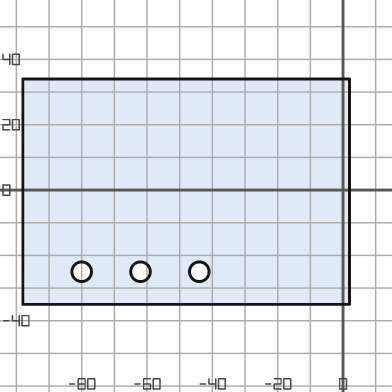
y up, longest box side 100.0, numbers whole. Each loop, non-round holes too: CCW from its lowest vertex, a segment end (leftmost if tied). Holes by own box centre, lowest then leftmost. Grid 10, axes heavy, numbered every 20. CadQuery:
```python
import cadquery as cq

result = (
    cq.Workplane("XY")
    .moveTo(-98.0, -35.0)
    .lineTo(2.0, -35.0)
    .lineTo(2.0, 34.0)
    .lineTo(-98.0, 34.0)
    .close()
    .moveTo(-80.0, -25.0)
    .circle(3.0)
    .moveTo(-62.0, -25.0)
    .circle(3.0)
    .moveTo(-44.0, -25.0)
    .circle(3.0)
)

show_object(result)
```